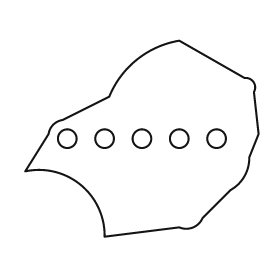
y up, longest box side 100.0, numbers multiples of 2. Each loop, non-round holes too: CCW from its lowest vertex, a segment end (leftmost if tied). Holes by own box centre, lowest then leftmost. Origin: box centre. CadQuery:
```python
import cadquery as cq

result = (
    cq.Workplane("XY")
    .moveTo(-16.0, -42.0)
    .lineTo(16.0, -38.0)
    .threePointArc((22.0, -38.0), (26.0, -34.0))
    .lineTo(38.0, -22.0)
    .threePointArc((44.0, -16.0), (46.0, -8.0))
    .lineTo(50.0, 2.0)
    .lineTo(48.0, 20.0)
    .threePointArc((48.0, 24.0), (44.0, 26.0))
    .lineTo(16.0, 42.0)
    .threePointArc((-2.0, 34.0), (-14.0, 18.0))
    .lineTo(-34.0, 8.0)
    .threePointArc((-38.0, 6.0), (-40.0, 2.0))
    .lineTo(-50.0, -14.0)
    .threePointArc((-26.0, -20.0), (-16.0, -42.0))
    .close()
    .moveTo(-32.0, 0.0)
    .circle(4.0)
    .moveTo(-16.0, 0.0)
    .circle(4.0)
    .moveTo(0.0, 0.0)
    .circle(4.0)
    .moveTo(16.0, 0.0)
    .circle(4.0)
    .moveTo(32.0, 0.0)
    .circle(4.0)
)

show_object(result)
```